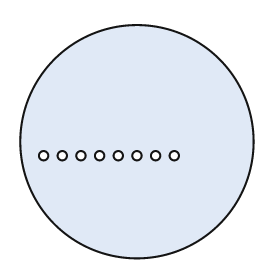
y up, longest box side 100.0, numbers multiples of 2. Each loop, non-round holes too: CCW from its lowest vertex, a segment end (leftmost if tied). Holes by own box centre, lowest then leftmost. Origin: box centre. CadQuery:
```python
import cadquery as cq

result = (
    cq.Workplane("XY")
    .moveTo(0.0, 0.0)
    .circle(50.0)
    .moveTo(-40.0, -6.0)
    .circle(2.0)
    .moveTo(-32.0, -6.0)
    .circle(2.0)
    .moveTo(-24.0, -6.0)
    .circle(2.0)
    .moveTo(-16.0, -6.0)
    .circle(2.0)
    .moveTo(-8.0, -6.0)
    .circle(2.0)
    .moveTo(0.0, -6.0)
    .circle(2.0)
    .moveTo(8.0, -6.0)
    .circle(2.0)
    .moveTo(16.0, -6.0)
    .circle(2.0)
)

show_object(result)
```